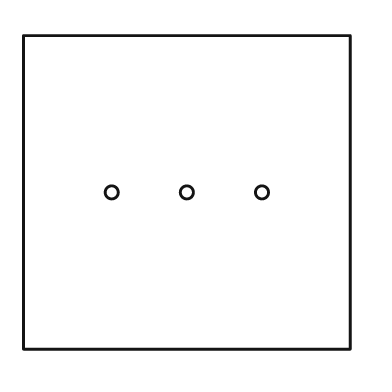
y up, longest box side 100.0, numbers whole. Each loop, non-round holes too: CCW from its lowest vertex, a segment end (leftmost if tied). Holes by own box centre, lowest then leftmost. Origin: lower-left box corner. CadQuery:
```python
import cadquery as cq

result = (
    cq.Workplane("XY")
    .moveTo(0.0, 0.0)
    .lineTo(100.0, 0.0)
    .lineTo(100.0, 96.0)
    .lineTo(0.0, 96.0)
    .close()
    .moveTo(27.0, 48.0)
    .circle(2.0)
    .moveTo(50.0, 48.0)
    .circle(2.0)
    .moveTo(73.0, 48.0)
    .circle(2.0)
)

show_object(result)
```